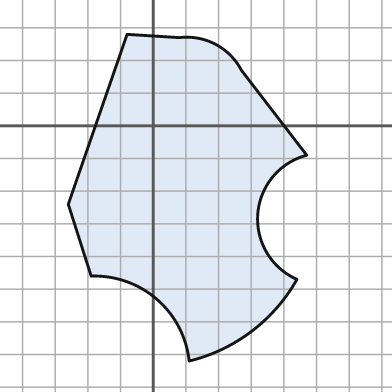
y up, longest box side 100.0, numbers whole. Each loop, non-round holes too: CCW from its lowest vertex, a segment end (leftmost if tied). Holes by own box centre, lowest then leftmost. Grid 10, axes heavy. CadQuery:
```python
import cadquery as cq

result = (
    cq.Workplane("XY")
    .moveTo(11.0, -72.0)
    .threePointArc((30.0, -63.0), (44.0, -47.0))
    .threePointArc((32.0, -27.0), (47.0, -9.0))
    .lineTo(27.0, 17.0)
    .threePointArc((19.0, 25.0), (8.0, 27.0))
    .lineTo(-8.0, 28.0)
    .lineTo(-26.0, -24.0)
    .lineTo(-19.0, -46.0)
    .threePointArc((1.0, -53.0), (11.0, -72.0))
    .close()
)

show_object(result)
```